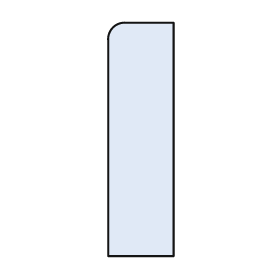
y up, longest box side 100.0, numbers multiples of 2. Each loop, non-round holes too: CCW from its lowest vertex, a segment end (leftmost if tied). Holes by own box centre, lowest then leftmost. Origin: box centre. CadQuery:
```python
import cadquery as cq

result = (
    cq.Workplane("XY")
    .moveTo(-14.0, -50.0)
    .lineTo(14.0, -50.0)
    .lineTo(14.0, 50.0)
    .lineTo(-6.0, 50.0)
    .threePointArc((-12.0, 48.0), (-14.0, 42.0))
    .close()
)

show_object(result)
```